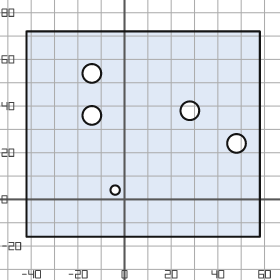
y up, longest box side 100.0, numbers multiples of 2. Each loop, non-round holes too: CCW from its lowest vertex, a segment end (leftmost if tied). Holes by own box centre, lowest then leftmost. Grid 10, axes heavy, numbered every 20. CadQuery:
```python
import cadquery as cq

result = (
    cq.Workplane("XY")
    .moveTo(-42.0, -16.0)
    .lineTo(58.0, -16.0)
    .lineTo(58.0, 72.0)
    .lineTo(-42.0, 72.0)
    .close()
    .moveTo(-4.0, 4.0)
    .circle(2.0)
    .moveTo(48.0, 24.0)
    .circle(4.0)
    .moveTo(-14.0, 36.0)
    .circle(4.0)
    .moveTo(28.0, 38.0)
    .circle(4.0)
    .moveTo(-14.0, 54.0)
    .circle(4.0)
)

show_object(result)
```